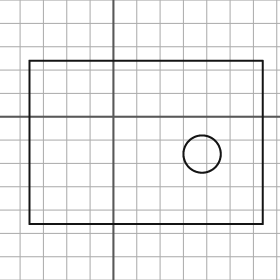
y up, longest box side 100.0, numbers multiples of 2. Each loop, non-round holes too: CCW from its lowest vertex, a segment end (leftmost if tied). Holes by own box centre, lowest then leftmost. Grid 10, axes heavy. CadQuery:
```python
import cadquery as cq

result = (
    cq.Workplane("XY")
    .moveTo(-36.0, -46.0)
    .lineTo(64.0, -46.0)
    .lineTo(64.0, 24.0)
    .lineTo(-36.0, 24.0)
    .close()
    .moveTo(38.0, -16.0)
    .circle(8.0)
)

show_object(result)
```